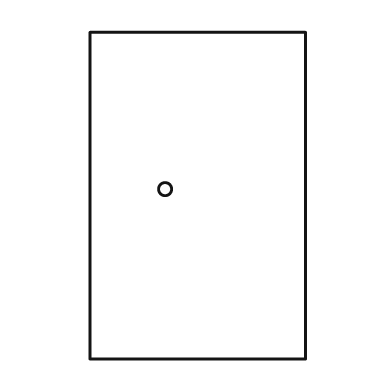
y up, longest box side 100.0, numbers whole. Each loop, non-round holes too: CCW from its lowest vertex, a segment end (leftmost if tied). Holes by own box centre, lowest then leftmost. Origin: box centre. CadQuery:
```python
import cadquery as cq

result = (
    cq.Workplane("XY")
    .moveTo(-33.0, -50.0)
    .lineTo(33.0, -50.0)
    .lineTo(33.0, 50.0)
    .lineTo(-33.0, 50.0)
    .close()
    .moveTo(-10.0, 2.0)
    .circle(2.0)
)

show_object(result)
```